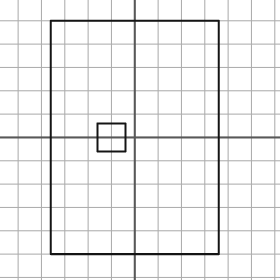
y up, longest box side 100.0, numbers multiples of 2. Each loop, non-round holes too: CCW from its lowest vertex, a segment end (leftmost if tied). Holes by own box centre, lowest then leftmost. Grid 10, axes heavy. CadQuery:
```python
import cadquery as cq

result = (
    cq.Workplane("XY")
    .moveTo(-36.0, -50.0)
    .lineTo(36.0, -50.0)
    .lineTo(36.0, 50.0)
    .lineTo(-36.0, 50.0)
    .close()
    .moveTo(-16.0, -6.0)
    .lineTo(-4.0, -6.0)
    .lineTo(-4.0, 6.0)
    .lineTo(-16.0, 6.0)
    .close()
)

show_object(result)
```